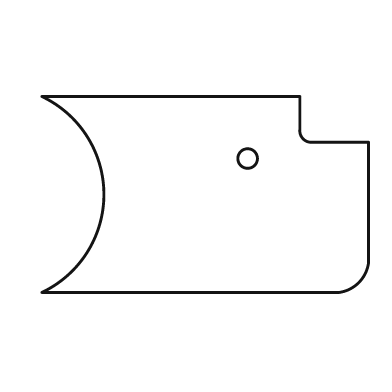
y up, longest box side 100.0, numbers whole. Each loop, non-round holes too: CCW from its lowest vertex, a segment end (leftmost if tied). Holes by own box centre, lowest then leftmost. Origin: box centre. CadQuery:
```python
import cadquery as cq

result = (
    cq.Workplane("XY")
    .moveTo(-50.0, -30.0)
    .lineTo(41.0, -30.0)
    .threePointArc((47.0, -27.0), (50.0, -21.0))
    .lineTo(50.0, 16.0)
    .lineTo(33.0, 16.0)
    .threePointArc((30.0, 17.0), (29.0, 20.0))
    .lineTo(29.0, 30.0)
    .lineTo(-50.0, 30.0)
    .threePointArc((-31.0, 0.0), (-50.0, -30.0))
    .close()
    .moveTo(13.0, 11.0)
    .circle(3.0)
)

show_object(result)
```